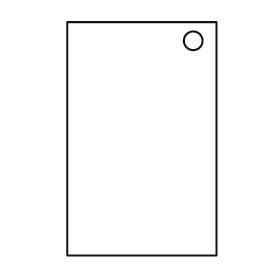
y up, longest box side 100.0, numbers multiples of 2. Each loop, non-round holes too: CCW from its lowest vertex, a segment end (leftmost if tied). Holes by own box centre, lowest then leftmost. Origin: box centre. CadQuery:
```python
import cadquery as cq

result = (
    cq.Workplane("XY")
    .moveTo(-32.0, -50.0)
    .lineTo(32.0, -50.0)
    .lineTo(32.0, 50.0)
    .lineTo(-32.0, 50.0)
    .close()
    .moveTo(22.0, 42.0)
    .circle(4.0)
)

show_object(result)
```